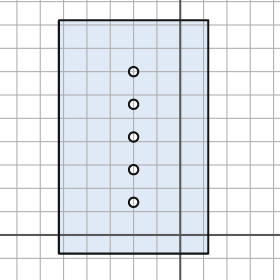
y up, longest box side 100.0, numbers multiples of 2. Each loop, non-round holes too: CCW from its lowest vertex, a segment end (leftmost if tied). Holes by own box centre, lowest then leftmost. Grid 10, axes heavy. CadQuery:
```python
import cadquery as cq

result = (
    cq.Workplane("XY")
    .moveTo(-52.0, -8.0)
    .lineTo(12.0, -8.0)
    .lineTo(12.0, 92.0)
    .lineTo(-52.0, 92.0)
    .close()
    .moveTo(-20.0, 14.0)
    .circle(2.0)
    .moveTo(-20.0, 28.0)
    .circle(2.0)
    .moveTo(-20.0, 42.0)
    .circle(2.0)
    .moveTo(-20.0, 56.0)
    .circle(2.0)
    .moveTo(-20.0, 70.0)
    .circle(2.0)
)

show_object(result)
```